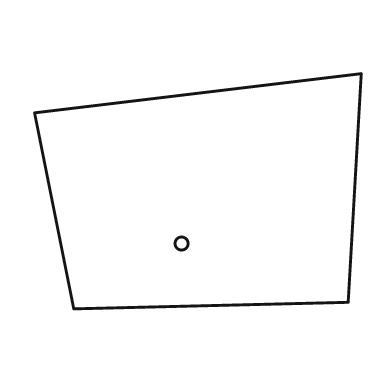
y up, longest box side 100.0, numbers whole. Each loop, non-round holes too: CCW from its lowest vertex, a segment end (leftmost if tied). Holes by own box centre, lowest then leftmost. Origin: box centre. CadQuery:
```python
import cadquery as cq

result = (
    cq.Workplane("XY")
    .moveTo(-38.0, -36.0)
    .lineTo(46.0, -34.0)
    .lineTo(50.0, 36.0)
    .lineTo(-50.0, 24.0)
    .close()
    .moveTo(-5.0, -16.0)
    .circle(2.0)
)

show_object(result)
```